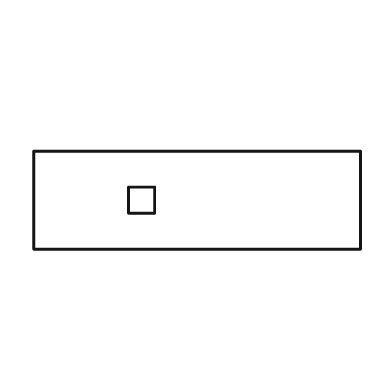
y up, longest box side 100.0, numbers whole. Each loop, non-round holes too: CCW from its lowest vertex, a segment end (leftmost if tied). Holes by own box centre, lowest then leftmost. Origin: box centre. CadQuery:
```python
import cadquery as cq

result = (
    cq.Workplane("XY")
    .moveTo(-50.0, -15.0)
    .lineTo(50.0, -15.0)
    .lineTo(50.0, 15.0)
    .lineTo(-50.0, 15.0)
    .close()
    .moveTo(-21.0, -4.0)
    .lineTo(-13.0, -4.0)
    .lineTo(-13.0, 4.0)
    .lineTo(-21.0, 4.0)
    .close()
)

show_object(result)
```